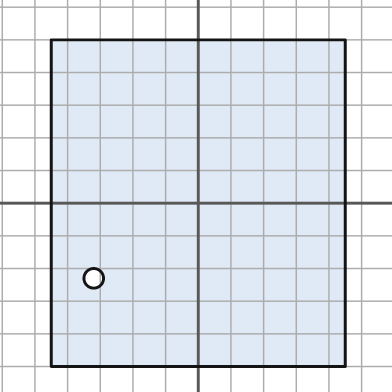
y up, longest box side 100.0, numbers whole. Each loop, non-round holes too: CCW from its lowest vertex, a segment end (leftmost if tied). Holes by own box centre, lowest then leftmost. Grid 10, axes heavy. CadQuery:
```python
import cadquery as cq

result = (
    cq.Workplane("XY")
    .moveTo(-45.0, -50.0)
    .lineTo(45.0, -50.0)
    .lineTo(45.0, 50.0)
    .lineTo(-45.0, 50.0)
    .close()
    .moveTo(-32.0, -23.0)
    .circle(3.0)
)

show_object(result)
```